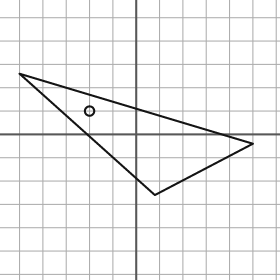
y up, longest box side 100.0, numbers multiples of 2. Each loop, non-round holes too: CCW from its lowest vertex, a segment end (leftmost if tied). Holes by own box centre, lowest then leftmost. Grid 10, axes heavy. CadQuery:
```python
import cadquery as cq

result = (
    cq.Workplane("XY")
    .moveTo(8.0, -26.0)
    .lineTo(50.0, -4.0)
    .lineTo(-50.0, 26.0)
    .close()
    .moveTo(-20.0, 10.0)
    .circle(2.0)
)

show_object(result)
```